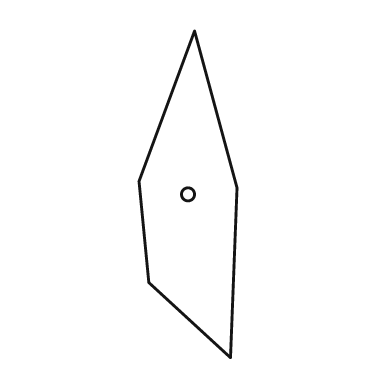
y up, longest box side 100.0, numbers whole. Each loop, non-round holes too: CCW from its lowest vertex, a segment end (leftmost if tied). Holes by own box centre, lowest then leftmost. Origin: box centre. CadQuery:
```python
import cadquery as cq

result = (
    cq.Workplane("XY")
    .moveTo(13.0, -50.0)
    .lineTo(15.0, 2.0)
    .lineTo(2.0, 50.0)
    .lineTo(-15.0, 4.0)
    .lineTo(-12.0, -27.0)
    .close()
    .moveTo(0.0, 0.0)
    .circle(2.0)
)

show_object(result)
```